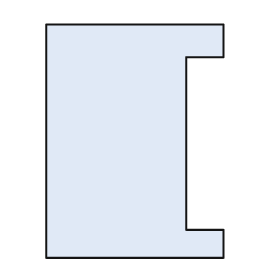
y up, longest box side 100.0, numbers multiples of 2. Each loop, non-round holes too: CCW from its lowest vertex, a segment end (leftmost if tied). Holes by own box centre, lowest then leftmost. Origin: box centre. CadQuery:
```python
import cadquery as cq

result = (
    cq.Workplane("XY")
    .moveTo(-38.0, -50.0)
    .lineTo(38.0, -50.0)
    .lineTo(38.0, -38.0)
    .lineTo(22.0, -38.0)
    .lineTo(22.0, 36.0)
    .lineTo(38.0, 36.0)
    .lineTo(38.0, 50.0)
    .lineTo(-38.0, 50.0)
    .close()
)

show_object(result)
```